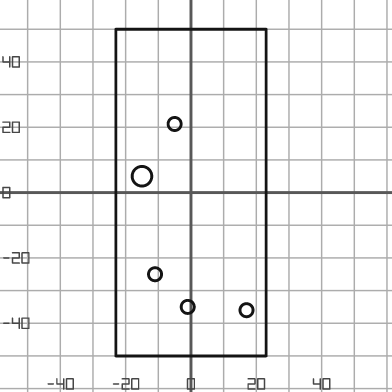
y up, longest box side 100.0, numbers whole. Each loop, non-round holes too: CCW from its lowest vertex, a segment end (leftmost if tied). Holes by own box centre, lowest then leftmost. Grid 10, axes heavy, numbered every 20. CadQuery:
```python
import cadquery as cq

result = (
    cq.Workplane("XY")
    .moveTo(-23.0, -50.0)
    .lineTo(23.0, -50.0)
    .lineTo(23.0, 50.0)
    .lineTo(-23.0, 50.0)
    .close()
    .moveTo(17.0, -36.0)
    .circle(2.0)
    .moveTo(-1.0, -35.0)
    .circle(2.0)
    .moveTo(-11.0, -25.0)
    .circle(2.0)
    .moveTo(-15.0, 5.0)
    .circle(3.0)
    .moveTo(-5.0, 21.0)
    .circle(2.0)
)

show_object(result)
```